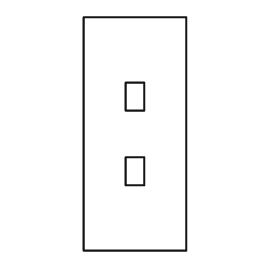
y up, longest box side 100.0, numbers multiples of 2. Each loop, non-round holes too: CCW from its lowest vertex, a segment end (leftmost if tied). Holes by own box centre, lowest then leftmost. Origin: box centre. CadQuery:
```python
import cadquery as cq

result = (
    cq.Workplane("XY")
    .moveTo(-22.0, -50.0)
    .lineTo(22.0, -50.0)
    .lineTo(22.0, 50.0)
    .lineTo(-22.0, 50.0)
    .close()
    .moveTo(-4.0, -22.0)
    .lineTo(4.0, -22.0)
    .lineTo(4.0, -10.0)
    .lineTo(-4.0, -10.0)
    .close()
    .moveTo(-4.0, 10.0)
    .lineTo(4.0, 10.0)
    .lineTo(4.0, 22.0)
    .lineTo(-4.0, 22.0)
    .close()
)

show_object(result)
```